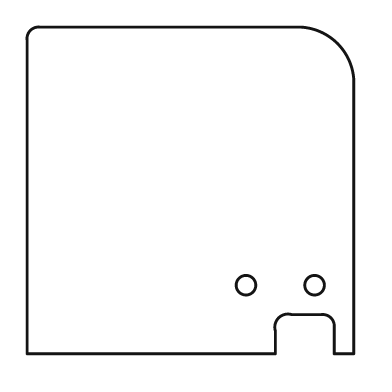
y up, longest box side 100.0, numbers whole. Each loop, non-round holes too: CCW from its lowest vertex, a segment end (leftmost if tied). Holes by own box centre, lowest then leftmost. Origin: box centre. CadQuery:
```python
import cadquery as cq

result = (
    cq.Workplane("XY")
    .moveTo(-50.0, -50.0)
    .lineTo(26.0, -50.0)
    .lineTo(26.0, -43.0)
    .threePointArc((27.0, -39.0), (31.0, -38.0))
    .lineTo(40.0, -38.0)
    .threePointArc((43.0, -39.0), (44.0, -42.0))
    .lineTo(44.0, -50.0)
    .lineTo(50.0, -50.0)
    .lineTo(50.0, 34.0)
    .threePointArc((45.0, 45.0), (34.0, 50.0))
    .lineTo(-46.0, 50.0)
    .threePointArc((-49.0, 49.0), (-50.0, 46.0))
    .close()
    .moveTo(17.0, -29.0)
    .circle(3.0)
    .moveTo(38.0, -29.0)
    .circle(3.0)
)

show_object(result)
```